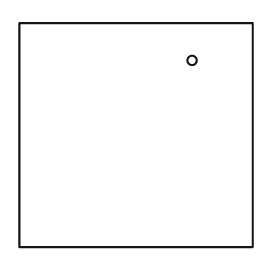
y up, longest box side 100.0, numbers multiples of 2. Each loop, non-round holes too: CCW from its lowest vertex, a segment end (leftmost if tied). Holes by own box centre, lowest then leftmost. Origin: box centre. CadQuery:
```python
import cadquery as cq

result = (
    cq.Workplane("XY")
    .moveTo(-50.0, -48.0)
    .lineTo(50.0, -48.0)
    .lineTo(50.0, 48.0)
    .lineTo(-50.0, 48.0)
    .close()
    .moveTo(24.0, 32.0)
    .circle(2.0)
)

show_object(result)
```